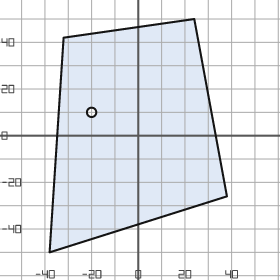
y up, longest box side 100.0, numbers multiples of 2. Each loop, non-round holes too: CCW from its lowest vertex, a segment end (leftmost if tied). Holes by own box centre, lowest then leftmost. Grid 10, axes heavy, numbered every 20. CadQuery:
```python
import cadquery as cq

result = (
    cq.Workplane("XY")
    .moveTo(-38.0, -50.0)
    .lineTo(38.0, -26.0)
    .lineTo(24.0, 50.0)
    .lineTo(-32.0, 42.0)
    .close()
    .moveTo(-20.0, 10.0)
    .circle(2.0)
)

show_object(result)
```